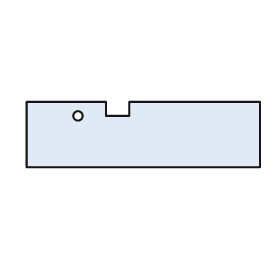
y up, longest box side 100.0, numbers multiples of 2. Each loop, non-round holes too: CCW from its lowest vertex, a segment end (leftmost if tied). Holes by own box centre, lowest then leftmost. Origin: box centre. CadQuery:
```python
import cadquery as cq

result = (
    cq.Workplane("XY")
    .moveTo(-50.0, -14.0)
    .lineTo(50.0, -14.0)
    .lineTo(50.0, 14.0)
    .lineTo(-6.0, 14.0)
    .lineTo(-6.0, 8.0)
    .lineTo(-16.0, 8.0)
    .lineTo(-16.0, 14.0)
    .lineTo(-50.0, 14.0)
    .close()
    .moveTo(-28.0, 8.0)
    .circle(2.0)
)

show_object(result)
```